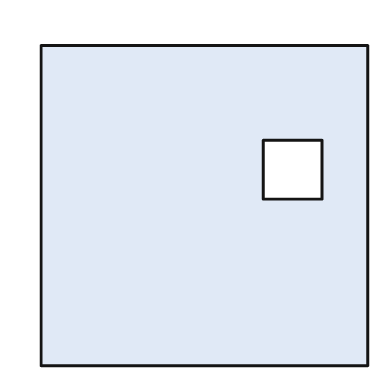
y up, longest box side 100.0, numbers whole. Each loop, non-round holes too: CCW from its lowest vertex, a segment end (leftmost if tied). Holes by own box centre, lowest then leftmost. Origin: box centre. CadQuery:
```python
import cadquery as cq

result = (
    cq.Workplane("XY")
    .moveTo(-50.0, -49.0)
    .lineTo(50.0, -49.0)
    .lineTo(50.0, 49.0)
    .lineTo(-50.0, 49.0)
    .close()
    .moveTo(18.0, 2.0)
    .lineTo(36.0, 2.0)
    .lineTo(36.0, 20.0)
    .lineTo(18.0, 20.0)
    .close()
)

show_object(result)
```